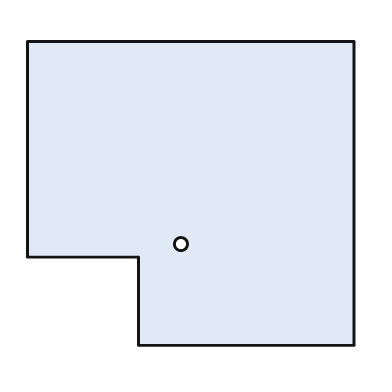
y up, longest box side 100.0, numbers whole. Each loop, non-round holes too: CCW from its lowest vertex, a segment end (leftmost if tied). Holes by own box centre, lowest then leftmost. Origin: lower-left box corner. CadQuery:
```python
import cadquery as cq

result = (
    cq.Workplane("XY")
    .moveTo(34.0, 0.0)
    .lineTo(100.0, 0.0)
    .lineTo(100.0, 93.0)
    .lineTo(0.0, 93.0)
    .lineTo(0.0, 27.0)
    .lineTo(34.0, 27.0)
    .close()
    .moveTo(47.0, 31.0)
    .circle(2.0)
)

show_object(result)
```